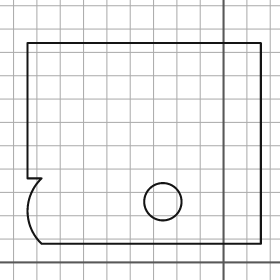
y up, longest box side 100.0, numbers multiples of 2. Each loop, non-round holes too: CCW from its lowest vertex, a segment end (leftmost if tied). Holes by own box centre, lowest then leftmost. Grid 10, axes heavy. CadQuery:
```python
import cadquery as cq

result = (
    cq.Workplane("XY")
    .moveTo(-78.0, 8.0)
    .lineTo(16.0, 8.0)
    .lineTo(16.0, 94.0)
    .lineTo(-84.0, 94.0)
    .lineTo(-84.0, 36.0)
    .lineTo(-78.0, 36.0)
    .threePointArc((-84.0, 22.0), (-78.0, 8.0))
    .close()
    .moveTo(-26.0, 26.0)
    .circle(8.0)
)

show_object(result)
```